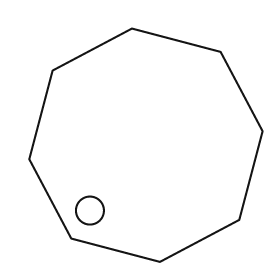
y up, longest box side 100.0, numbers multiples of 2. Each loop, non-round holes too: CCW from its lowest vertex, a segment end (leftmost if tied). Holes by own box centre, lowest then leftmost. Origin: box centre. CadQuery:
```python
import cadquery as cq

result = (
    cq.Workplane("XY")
    .moveTo(6.0, -50.0)
    .lineTo(40.0, -32.0)
    .lineTo(50.0, 6.0)
    .lineTo(32.0, 40.0)
    .lineTo(-6.0, 50.0)
    .lineTo(-40.0, 32.0)
    .lineTo(-50.0, -6.0)
    .lineTo(-32.0, -40.0)
    .close()
    .moveTo(-24.0, -28.0)
    .circle(6.0)
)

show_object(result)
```